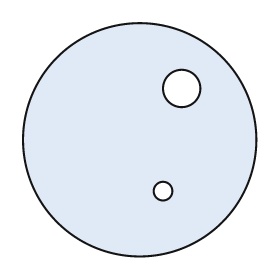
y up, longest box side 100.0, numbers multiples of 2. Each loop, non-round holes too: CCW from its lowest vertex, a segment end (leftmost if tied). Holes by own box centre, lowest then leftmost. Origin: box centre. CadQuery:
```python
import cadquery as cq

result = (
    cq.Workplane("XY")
    .moveTo(0.0, 0.0)
    .circle(50.0)
    .moveTo(10.0, -22.0)
    .circle(4.0)
    .moveTo(18.0, 22.0)
    .circle(8.0)
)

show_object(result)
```